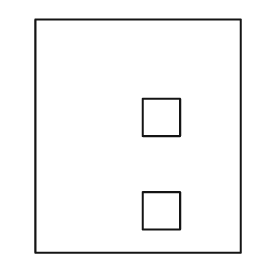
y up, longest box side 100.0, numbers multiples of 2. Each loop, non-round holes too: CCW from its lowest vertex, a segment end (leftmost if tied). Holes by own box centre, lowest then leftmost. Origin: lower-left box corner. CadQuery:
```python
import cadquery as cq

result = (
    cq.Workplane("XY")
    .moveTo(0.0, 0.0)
    .lineTo(88.0, 0.0)
    .lineTo(88.0, 100.0)
    .lineTo(0.0, 100.0)
    .close()
    .moveTo(46.0, 10.0)
    .lineTo(62.0, 10.0)
    .lineTo(62.0, 26.0)
    .lineTo(46.0, 26.0)
    .close()
    .moveTo(46.0, 50.0)
    .lineTo(62.0, 50.0)
    .lineTo(62.0, 66.0)
    .lineTo(46.0, 66.0)
    .close()
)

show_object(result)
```